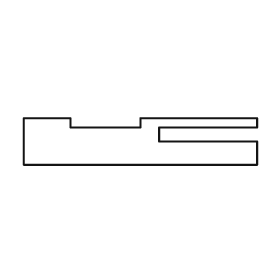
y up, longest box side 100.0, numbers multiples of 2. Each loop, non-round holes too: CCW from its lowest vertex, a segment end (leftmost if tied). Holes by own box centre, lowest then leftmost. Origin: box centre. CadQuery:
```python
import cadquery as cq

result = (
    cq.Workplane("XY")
    .moveTo(-50.0, -10.0)
    .lineTo(50.0, -10.0)
    .lineTo(50.0, 0.0)
    .lineTo(8.0, 0.0)
    .lineTo(8.0, 6.0)
    .lineTo(50.0, 6.0)
    .lineTo(50.0, 10.0)
    .lineTo(0.0, 10.0)
    .lineTo(0.0, 6.0)
    .lineTo(-30.0, 6.0)
    .lineTo(-30.0, 10.0)
    .lineTo(-50.0, 10.0)
    .close()
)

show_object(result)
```